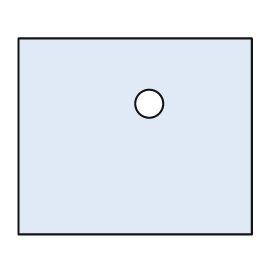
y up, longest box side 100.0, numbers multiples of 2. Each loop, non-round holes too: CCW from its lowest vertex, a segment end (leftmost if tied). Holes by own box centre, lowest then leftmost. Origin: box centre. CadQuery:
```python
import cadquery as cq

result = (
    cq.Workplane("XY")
    .moveTo(-50.0, -42.0)
    .lineTo(50.0, -42.0)
    .lineTo(50.0, 42.0)
    .lineTo(-50.0, 42.0)
    .close()
    .moveTo(6.0, 14.0)
    .circle(6.0)
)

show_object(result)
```